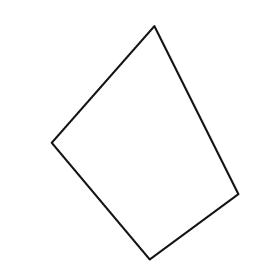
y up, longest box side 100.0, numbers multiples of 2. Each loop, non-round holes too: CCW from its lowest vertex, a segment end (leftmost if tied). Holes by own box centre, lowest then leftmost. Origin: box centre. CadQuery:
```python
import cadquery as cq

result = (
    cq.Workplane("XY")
    .moveTo(2.0, -50.0)
    .lineTo(40.0, -22.0)
    .lineTo(4.0, 50.0)
    .lineTo(-40.0, 0.0)
    .close()
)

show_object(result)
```